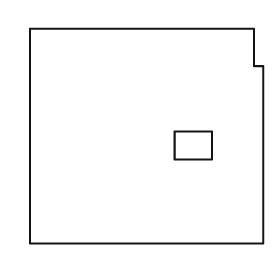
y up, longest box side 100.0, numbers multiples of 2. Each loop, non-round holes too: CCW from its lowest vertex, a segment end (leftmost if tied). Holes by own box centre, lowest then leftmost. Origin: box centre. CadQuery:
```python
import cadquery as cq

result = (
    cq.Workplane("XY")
    .moveTo(-50.0, -46.0)
    .lineTo(50.0, -46.0)
    .lineTo(50.0, 30.0)
    .lineTo(46.0, 30.0)
    .lineTo(46.0, 46.0)
    .lineTo(-50.0, 46.0)
    .close()
    .moveTo(12.0, -10.0)
    .lineTo(28.0, -10.0)
    .lineTo(28.0, 2.0)
    .lineTo(12.0, 2.0)
    .close()
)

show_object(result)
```